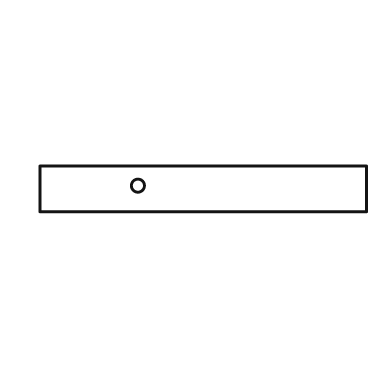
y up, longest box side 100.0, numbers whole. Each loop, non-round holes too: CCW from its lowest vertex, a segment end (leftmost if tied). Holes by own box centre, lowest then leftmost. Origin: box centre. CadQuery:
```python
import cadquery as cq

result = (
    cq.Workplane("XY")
    .moveTo(-50.0, -7.0)
    .lineTo(50.0, -7.0)
    .lineTo(50.0, 7.0)
    .lineTo(-50.0, 7.0)
    .close()
    .moveTo(-20.0, 1.0)
    .circle(2.0)
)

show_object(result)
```